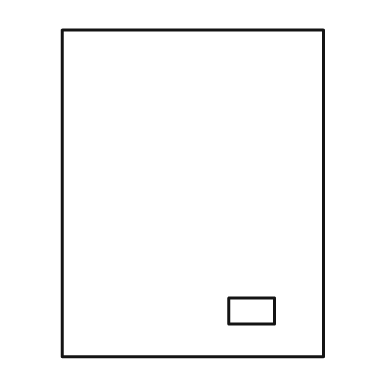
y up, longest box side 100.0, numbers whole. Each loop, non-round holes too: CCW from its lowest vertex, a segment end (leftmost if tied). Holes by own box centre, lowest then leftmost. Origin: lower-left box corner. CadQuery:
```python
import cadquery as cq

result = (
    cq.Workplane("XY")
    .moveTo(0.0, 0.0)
    .lineTo(80.0, 0.0)
    .lineTo(80.0, 100.0)
    .lineTo(0.0, 100.0)
    .close()
    .moveTo(51.0, 10.0)
    .lineTo(65.0, 10.0)
    .lineTo(65.0, 18.0)
    .lineTo(51.0, 18.0)
    .close()
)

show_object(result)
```